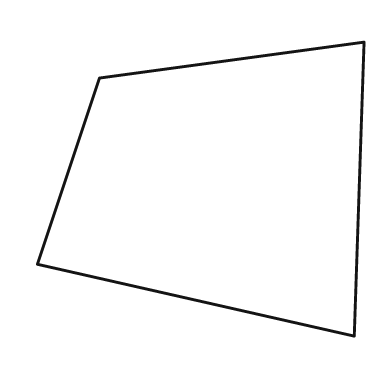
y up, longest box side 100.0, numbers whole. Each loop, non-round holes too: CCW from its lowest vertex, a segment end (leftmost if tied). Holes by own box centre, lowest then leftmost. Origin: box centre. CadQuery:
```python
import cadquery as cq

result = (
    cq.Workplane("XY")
    .moveTo(47.0, -45.0)
    .lineTo(50.0, 45.0)
    .lineTo(-31.0, 34.0)
    .lineTo(-50.0, -23.0)
    .close()
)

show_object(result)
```